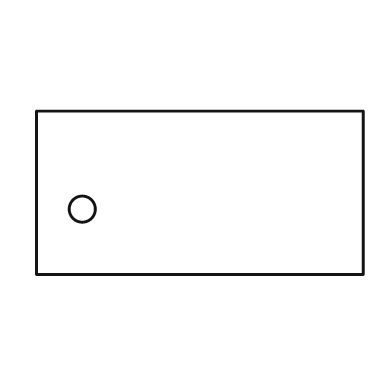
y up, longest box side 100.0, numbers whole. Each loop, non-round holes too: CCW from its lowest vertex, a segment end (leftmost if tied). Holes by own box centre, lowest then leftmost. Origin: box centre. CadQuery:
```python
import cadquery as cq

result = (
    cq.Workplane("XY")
    .moveTo(-50.0, -25.0)
    .lineTo(50.0, -25.0)
    .lineTo(50.0, 25.0)
    .lineTo(-50.0, 25.0)
    .close()
    .moveTo(-36.0, -5.0)
    .circle(4.0)
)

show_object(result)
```